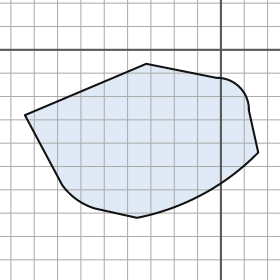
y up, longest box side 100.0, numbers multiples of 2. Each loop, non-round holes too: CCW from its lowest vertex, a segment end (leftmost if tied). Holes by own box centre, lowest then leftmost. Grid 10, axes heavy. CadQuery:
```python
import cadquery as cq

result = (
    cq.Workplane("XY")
    .moveTo(-36.0, -72.0)
    .threePointArc((-8.0, -62.0), (16.0, -44.0))
    .lineTo(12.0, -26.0)
    .threePointArc((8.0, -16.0), (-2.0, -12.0))
    .lineTo(-32.0, -6.0)
    .lineTo(-84.0, -28.0)
    .lineTo(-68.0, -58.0)
    .threePointArc((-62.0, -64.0), (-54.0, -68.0))
    .close()
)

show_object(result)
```